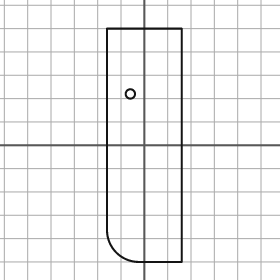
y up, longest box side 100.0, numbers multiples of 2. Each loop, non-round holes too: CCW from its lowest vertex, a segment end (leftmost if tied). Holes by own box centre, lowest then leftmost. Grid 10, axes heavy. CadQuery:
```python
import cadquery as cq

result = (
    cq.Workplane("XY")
    .moveTo(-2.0, -50.0)
    .lineTo(16.0, -50.0)
    .lineTo(16.0, 50.0)
    .lineTo(-16.0, 50.0)
    .lineTo(-16.0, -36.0)
    .threePointArc((-12.0, -46.0), (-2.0, -50.0))
    .close()
    .moveTo(-6.0, 22.0)
    .circle(2.0)
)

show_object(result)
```